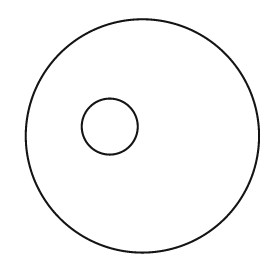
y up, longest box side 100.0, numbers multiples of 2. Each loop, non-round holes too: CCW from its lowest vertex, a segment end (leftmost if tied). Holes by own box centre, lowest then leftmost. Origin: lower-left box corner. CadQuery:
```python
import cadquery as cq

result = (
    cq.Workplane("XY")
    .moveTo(50.0, 50.0)
    .circle(50.0)
    .moveTo(36.0, 54.0)
    .circle(12.0)
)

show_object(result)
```